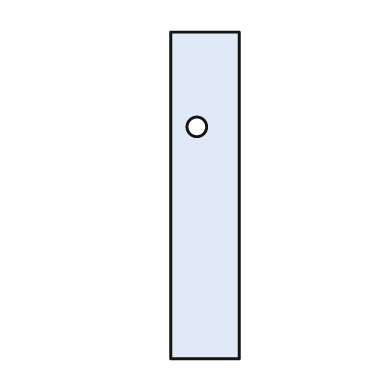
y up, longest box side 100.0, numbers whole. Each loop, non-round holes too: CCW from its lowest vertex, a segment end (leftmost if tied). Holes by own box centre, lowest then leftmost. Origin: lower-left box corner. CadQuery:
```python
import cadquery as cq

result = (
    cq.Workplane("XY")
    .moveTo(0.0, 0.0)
    .lineTo(21.0, 0.0)
    .lineTo(21.0, 100.0)
    .lineTo(0.0, 100.0)
    .close()
    .moveTo(8.0, 71.0)
    .circle(3.0)
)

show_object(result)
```